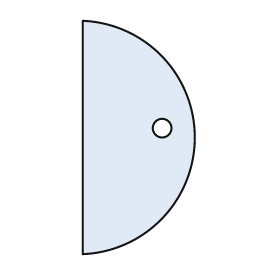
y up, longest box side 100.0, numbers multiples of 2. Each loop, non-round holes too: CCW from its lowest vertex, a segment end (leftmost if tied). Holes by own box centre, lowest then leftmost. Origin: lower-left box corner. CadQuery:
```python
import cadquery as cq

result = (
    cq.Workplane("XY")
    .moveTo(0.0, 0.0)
    .threePointArc((48.0, 50.0), (0.0, 100.0))
    .close()
    .moveTo(34.0, 54.0)
    .circle(4.0)
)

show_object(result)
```